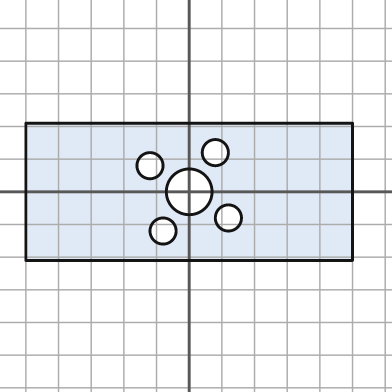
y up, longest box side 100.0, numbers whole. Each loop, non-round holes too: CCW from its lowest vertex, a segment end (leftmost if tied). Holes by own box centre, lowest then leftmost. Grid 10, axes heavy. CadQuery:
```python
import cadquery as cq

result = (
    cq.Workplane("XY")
    .moveTo(-50.0, -21.0)
    .lineTo(50.0, -21.0)
    .lineTo(50.0, 21.0)
    .lineTo(-50.0, 21.0)
    .close()
    .moveTo(-8.0, -12.0)
    .circle(4.0)
    .moveTo(12.0, -8.0)
    .circle(4.0)
    .moveTo(0.0, 0.0)
    .circle(7.0)
    .moveTo(-12.0, 8.0)
    .circle(4.0)
    .moveTo(8.0, 12.0)
    .circle(4.0)
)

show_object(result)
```